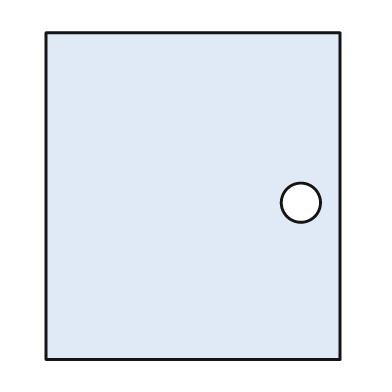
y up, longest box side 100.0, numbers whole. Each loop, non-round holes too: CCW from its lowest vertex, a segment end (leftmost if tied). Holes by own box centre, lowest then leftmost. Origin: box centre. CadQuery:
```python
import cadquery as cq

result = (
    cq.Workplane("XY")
    .moveTo(-45.0, -50.0)
    .lineTo(45.0, -50.0)
    .lineTo(45.0, 50.0)
    .lineTo(-45.0, 50.0)
    .close()
    .moveTo(33.0, -2.0)
    .circle(6.0)
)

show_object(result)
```